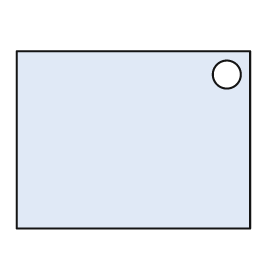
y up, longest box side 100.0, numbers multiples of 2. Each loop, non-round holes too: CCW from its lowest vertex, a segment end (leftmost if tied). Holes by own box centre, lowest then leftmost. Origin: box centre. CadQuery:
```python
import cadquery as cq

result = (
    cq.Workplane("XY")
    .moveTo(-50.0, -38.0)
    .lineTo(50.0, -38.0)
    .lineTo(50.0, 38.0)
    .lineTo(-50.0, 38.0)
    .close()
    .moveTo(40.0, 28.0)
    .circle(6.0)
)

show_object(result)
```